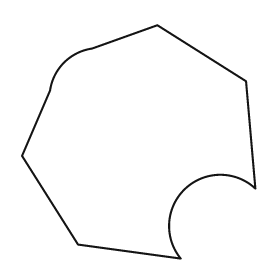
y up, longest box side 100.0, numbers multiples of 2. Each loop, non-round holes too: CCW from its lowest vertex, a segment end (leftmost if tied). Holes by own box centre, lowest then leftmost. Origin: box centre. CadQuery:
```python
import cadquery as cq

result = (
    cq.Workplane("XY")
    .moveTo(18.0, -50.0)
    .threePointArc((20.0, -20.0), (50.0, -20.0))
    .lineTo(46.0, 26.0)
    .lineTo(8.0, 50.0)
    .lineTo(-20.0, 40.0)
    .threePointArc((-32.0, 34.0), (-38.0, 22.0))
    .lineTo(-50.0, -6.0)
    .lineTo(-26.0, -44.0)
    .close()
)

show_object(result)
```